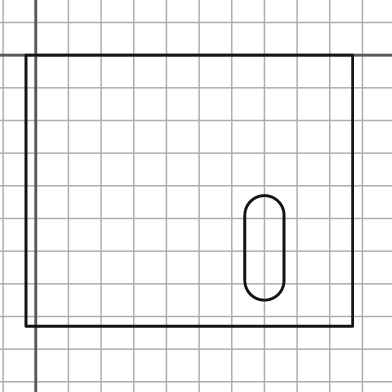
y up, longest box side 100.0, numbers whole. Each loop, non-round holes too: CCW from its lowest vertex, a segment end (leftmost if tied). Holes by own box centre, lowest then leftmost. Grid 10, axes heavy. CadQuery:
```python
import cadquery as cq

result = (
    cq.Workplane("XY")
    .moveTo(-3.0, -83.0)
    .lineTo(97.0, -83.0)
    .lineTo(97.0, 0.0)
    .lineTo(-3.0, 0.0)
    .close()
    .moveTo(64.0, -69.0)
    .threePointArc((70.0, -75.0), (76.0, -69.0))
    .lineTo(76.0, -49.0)
    .threePointArc((70.0, -43.0), (64.0, -49.0))
    .close()
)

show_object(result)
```